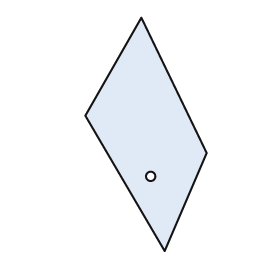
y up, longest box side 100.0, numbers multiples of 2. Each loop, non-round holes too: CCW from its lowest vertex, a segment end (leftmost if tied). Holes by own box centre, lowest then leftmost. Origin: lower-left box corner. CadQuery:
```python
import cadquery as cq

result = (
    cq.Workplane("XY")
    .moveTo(34.0, 0.0)
    .lineTo(52.0, 42.0)
    .lineTo(24.0, 100.0)
    .lineTo(0.0, 58.0)
    .close()
    .moveTo(28.0, 32.0)
    .circle(2.0)
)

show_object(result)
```